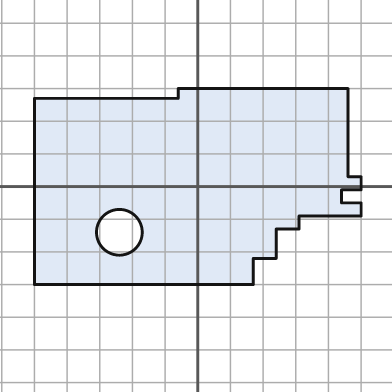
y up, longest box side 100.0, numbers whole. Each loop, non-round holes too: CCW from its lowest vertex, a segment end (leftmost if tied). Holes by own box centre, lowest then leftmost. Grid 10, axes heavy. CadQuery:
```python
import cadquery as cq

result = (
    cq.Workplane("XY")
    .moveTo(-50.0, -30.0)
    .lineTo(17.0, -30.0)
    .lineTo(17.0, -22.0)
    .lineTo(24.0, -22.0)
    .lineTo(24.0, -13.0)
    .lineTo(31.0, -13.0)
    .lineTo(31.0, -9.0)
    .lineTo(50.0, -9.0)
    .lineTo(50.0, -5.0)
    .lineTo(44.0, -5.0)
    .lineTo(44.0, -1.0)
    .lineTo(50.0, -1.0)
    .lineTo(50.0, 3.0)
    .lineTo(46.0, 3.0)
    .lineTo(46.0, 30.0)
    .lineTo(-6.0, 30.0)
    .lineTo(-6.0, 27.0)
    .lineTo(-50.0, 27.0)
    .close()
    .moveTo(-24.0, -14.0)
    .circle(7.0)
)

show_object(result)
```